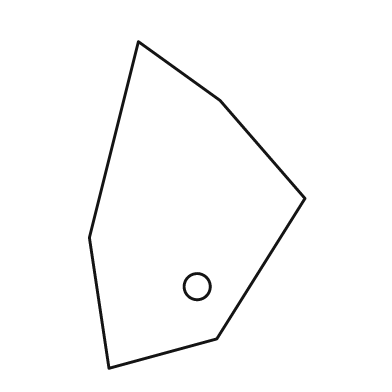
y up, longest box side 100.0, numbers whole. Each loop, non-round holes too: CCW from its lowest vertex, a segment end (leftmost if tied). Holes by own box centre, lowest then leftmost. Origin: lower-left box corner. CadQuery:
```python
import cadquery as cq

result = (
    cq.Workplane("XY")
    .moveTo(6.0, 0.0)
    .lineTo(39.0, 9.0)
    .lineTo(66.0, 52.0)
    .lineTo(40.0, 82.0)
    .lineTo(15.0, 100.0)
    .lineTo(0.0, 40.0)
    .close()
    .moveTo(33.0, 25.0)
    .circle(4.0)
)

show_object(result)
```